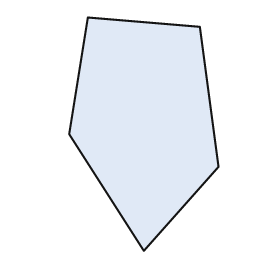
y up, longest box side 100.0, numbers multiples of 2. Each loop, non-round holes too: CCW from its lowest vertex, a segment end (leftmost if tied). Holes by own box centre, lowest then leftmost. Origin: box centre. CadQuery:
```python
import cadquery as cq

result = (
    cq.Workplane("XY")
    .moveTo(0.0, -50.0)
    .lineTo(32.0, -14.0)
    .lineTo(24.0, 46.0)
    .lineTo(-24.0, 50.0)
    .lineTo(-32.0, 0.0)
    .close()
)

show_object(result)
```